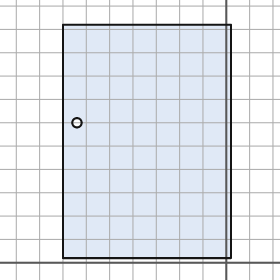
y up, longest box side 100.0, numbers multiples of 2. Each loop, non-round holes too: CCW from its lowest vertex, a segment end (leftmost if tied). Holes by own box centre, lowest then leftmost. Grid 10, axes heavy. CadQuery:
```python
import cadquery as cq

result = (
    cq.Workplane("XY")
    .moveTo(-70.0, 2.0)
    .lineTo(2.0, 2.0)
    .lineTo(2.0, 102.0)
    .lineTo(-70.0, 102.0)
    .close()
    .moveTo(-64.0, 60.0)
    .circle(2.0)
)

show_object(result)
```